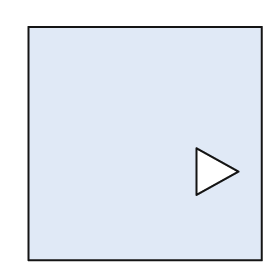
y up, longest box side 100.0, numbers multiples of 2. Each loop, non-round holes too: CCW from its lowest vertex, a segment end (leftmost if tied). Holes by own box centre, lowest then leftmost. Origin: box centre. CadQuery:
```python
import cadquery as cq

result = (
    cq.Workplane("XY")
    .moveTo(-50.0, -50.0)
    .lineTo(50.0, -50.0)
    .lineTo(50.0, 50.0)
    .lineTo(-50.0, 50.0)
    .close()
    .moveTo(22.0, -22.0)
    .lineTo(40.0, -12.0)
    .lineTo(22.0, -2.0)
    .close()
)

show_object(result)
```